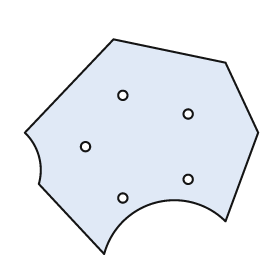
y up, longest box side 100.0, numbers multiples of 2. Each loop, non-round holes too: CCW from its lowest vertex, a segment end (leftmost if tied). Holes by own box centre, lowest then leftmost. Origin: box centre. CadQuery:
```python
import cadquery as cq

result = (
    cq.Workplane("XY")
    .moveTo(-16.0, -46.0)
    .threePointArc((6.0, -24.0), (36.0, -32.0))
    .lineTo(50.0, 6.0)
    .lineTo(36.0, 36.0)
    .lineTo(-12.0, 46.0)
    .lineTo(-50.0, 6.0)
    .threePointArc((-44.0, -4.0), (-44.0, -16.0))
    .close()
    .moveTo(-8.0, -22.0)
    .circle(2.0)
    .moveTo(20.0, -14.0)
    .circle(2.0)
    .moveTo(-24.0, 0.0)
    .circle(2.0)
    .moveTo(20.0, 14.0)
    .circle(2.0)
    .moveTo(-8.0, 22.0)
    .circle(2.0)
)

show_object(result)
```